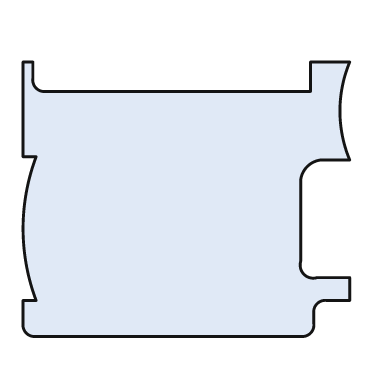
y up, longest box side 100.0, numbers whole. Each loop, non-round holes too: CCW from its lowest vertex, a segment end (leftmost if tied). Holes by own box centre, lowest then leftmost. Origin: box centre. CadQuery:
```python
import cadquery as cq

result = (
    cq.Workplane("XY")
    .moveTo(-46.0, -42.0)
    .lineTo(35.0, -42.0)
    .threePointArc((38.0, -41.0), (39.0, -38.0))
    .lineTo(39.0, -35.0)
    .threePointArc((40.0, -32.0), (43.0, -31.0))
    .lineTo(50.0, -31.0)
    .lineTo(50.0, -24.0)
    .lineTo(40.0, -24.0)
    .threePointArc((36.0, -23.0), (35.0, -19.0))
    .lineTo(35.0, 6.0)
    .threePointArc((37.0, 10.0), (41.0, 12.0))
    .lineTo(50.0, 12.0)
    .threePointArc((47.0, 27.0), (50.0, 42.0))
    .lineTo(38.0, 42.0)
    .lineTo(38.0, 33.0)
    .lineTo(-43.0, 33.0)
    .threePointArc((-46.0, 34.0), (-47.0, 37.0))
    .lineTo(-47.0, 42.0)
    .lineTo(-50.0, 42.0)
    .lineTo(-50.0, 13.0)
    .lineTo(-46.0, 13.0)
    .threePointArc((-50.0, -9.0), (-46.0, -31.0))
    .lineTo(-50.0, -31.0)
    .lineTo(-50.0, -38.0)
    .threePointArc((-49.0, -41.0), (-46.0, -42.0))
    .close()
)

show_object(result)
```